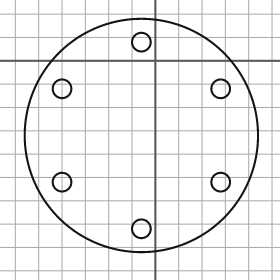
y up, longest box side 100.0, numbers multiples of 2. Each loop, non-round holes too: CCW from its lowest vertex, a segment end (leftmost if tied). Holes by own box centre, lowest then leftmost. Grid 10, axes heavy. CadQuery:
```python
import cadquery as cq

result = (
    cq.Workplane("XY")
    .moveTo(-6.0, -32.0)
    .circle(50.0)
    .moveTo(-6.0, -72.0)
    .circle(4.0)
    .moveTo(-40.0, -52.0)
    .circle(4.0)
    .moveTo(28.0, -52.0)
    .circle(4.0)
    .moveTo(-40.0, -12.0)
    .circle(4.0)
    .moveTo(28.0, -12.0)
    .circle(4.0)
    .moveTo(-6.0, 8.0)
    .circle(4.0)
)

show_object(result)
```